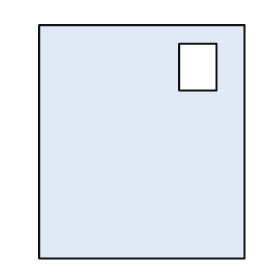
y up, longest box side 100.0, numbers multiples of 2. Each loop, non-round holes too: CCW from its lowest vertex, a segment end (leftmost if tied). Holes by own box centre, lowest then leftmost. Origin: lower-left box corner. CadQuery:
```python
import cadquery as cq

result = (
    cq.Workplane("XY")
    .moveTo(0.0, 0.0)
    .lineTo(88.0, 0.0)
    .lineTo(88.0, 100.0)
    .lineTo(0.0, 100.0)
    .close()
    .moveTo(60.0, 72.0)
    .lineTo(76.0, 72.0)
    .lineTo(76.0, 92.0)
    .lineTo(60.0, 92.0)
    .close()
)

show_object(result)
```